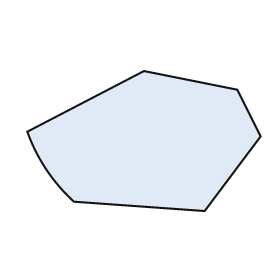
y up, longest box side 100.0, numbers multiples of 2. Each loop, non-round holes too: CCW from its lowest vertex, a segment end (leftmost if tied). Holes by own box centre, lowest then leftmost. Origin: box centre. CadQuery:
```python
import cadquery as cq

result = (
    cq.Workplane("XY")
    .moveTo(26.0, -30.0)
    .lineTo(50.0, 2.0)
    .lineTo(40.0, 22.0)
    .lineTo(0.0, 30.0)
    .lineTo(-50.0, 4.0)
    .threePointArc((-42.0, -12.0), (-30.0, -26.0))
    .close()
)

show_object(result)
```